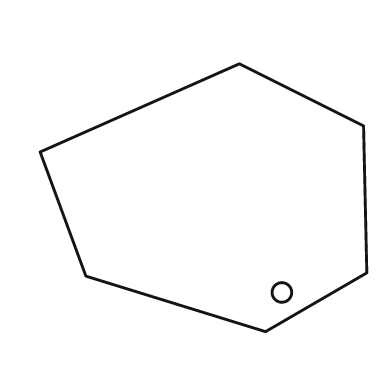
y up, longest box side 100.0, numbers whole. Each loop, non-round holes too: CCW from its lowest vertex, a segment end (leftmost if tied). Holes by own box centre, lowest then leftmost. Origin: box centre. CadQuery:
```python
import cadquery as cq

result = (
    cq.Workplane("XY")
    .moveTo(19.0, -41.0)
    .lineTo(50.0, -23.0)
    .lineTo(49.0, 22.0)
    .lineTo(11.0, 41.0)
    .lineTo(-50.0, 14.0)
    .lineTo(-36.0, -24.0)
    .close()
    .moveTo(24.0, -29.0)
    .circle(3.0)
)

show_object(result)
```